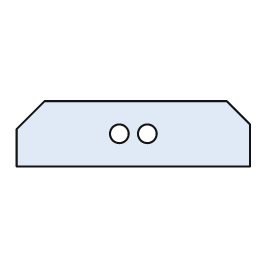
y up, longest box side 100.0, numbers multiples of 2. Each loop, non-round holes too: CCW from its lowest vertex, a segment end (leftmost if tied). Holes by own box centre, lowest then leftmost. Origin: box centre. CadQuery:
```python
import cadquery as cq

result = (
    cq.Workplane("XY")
    .moveTo(-50.0, -14.0)
    .lineTo(50.0, -14.0)
    .lineTo(50.0, 4.0)
    .lineTo(40.0, 14.0)
    .lineTo(-38.0, 14.0)
    .lineTo(-50.0, 2.0)
    .close()
    .moveTo(-6.0, 0.0)
    .circle(4.0)
    .moveTo(6.0, 0.0)
    .circle(4.0)
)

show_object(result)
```